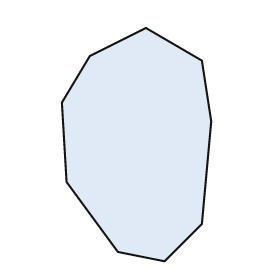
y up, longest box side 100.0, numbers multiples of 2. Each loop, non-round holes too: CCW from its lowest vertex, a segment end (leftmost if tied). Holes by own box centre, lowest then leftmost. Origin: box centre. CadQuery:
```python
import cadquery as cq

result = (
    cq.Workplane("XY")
    .moveTo(12.0, -50.0)
    .lineTo(28.0, -34.0)
    .lineTo(32.0, 10.0)
    .lineTo(28.0, 36.0)
    .lineTo(4.0, 50.0)
    .lineTo(-20.0, 38.0)
    .lineTo(-32.0, 18.0)
    .lineTo(-30.0, -16.0)
    .lineTo(-8.0, -46.0)
    .close()
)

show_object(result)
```